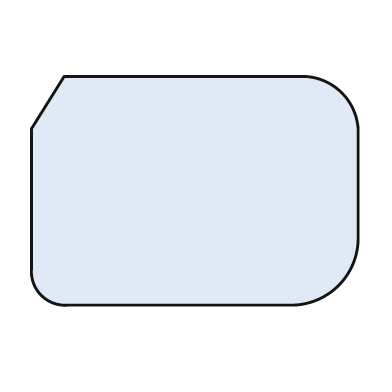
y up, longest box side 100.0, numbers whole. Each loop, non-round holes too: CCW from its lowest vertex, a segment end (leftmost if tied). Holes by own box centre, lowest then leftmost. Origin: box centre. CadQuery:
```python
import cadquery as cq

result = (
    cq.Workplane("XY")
    .moveTo(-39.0, -35.0)
    .lineTo(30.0, -35.0)
    .threePointArc((44.0, -29.0), (50.0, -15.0))
    .lineTo(50.0, 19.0)
    .threePointArc((45.0, 30.0), (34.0, 35.0))
    .lineTo(-40.0, 35.0)
    .lineTo(-50.0, 19.0)
    .lineTo(-50.0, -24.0)
    .threePointArc((-47.0, -32.0), (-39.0, -35.0))
    .close()
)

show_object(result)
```